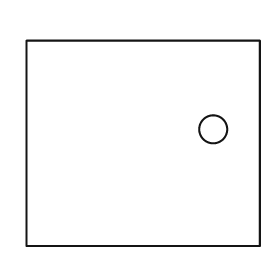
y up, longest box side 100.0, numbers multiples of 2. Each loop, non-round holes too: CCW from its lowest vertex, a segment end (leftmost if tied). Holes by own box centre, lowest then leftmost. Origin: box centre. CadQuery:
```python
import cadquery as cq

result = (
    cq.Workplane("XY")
    .moveTo(-50.0, -44.0)
    .lineTo(50.0, -44.0)
    .lineTo(50.0, 44.0)
    .lineTo(-50.0, 44.0)
    .close()
    .moveTo(30.0, 6.0)
    .circle(6.0)
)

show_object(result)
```